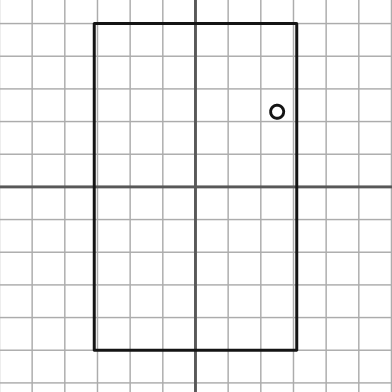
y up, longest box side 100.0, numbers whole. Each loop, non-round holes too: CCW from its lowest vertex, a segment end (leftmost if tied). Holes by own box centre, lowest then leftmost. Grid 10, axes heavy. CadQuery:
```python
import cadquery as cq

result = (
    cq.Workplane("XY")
    .moveTo(-31.0, -50.0)
    .lineTo(31.0, -50.0)
    .lineTo(31.0, 50.0)
    .lineTo(-31.0, 50.0)
    .close()
    .moveTo(25.0, 23.0)
    .circle(2.0)
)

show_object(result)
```